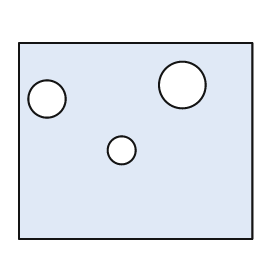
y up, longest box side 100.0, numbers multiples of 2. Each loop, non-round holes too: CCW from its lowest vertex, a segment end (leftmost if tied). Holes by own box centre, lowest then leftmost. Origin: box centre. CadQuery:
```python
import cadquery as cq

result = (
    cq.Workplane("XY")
    .moveTo(-50.0, -42.0)
    .lineTo(50.0, -42.0)
    .lineTo(50.0, 42.0)
    .lineTo(-50.0, 42.0)
    .close()
    .moveTo(-6.0, -4.0)
    .circle(6.0)
    .moveTo(-38.0, 18.0)
    .circle(8.0)
    .moveTo(20.0, 24.0)
    .circle(10.0)
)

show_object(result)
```